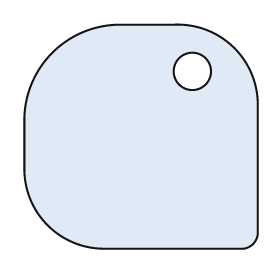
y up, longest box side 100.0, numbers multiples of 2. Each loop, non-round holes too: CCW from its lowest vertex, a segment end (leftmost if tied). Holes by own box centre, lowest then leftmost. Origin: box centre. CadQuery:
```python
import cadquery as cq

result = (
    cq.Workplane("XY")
    .moveTo(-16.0, -48.0)
    .lineTo(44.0, -48.0)
    .threePointArc((48.0, -46.0), (50.0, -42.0))
    .lineTo(50.0, 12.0)
    .threePointArc((40.0, 38.0), (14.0, 48.0))
    .lineTo(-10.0, 48.0)
    .threePointArc((-38.0, 36.0), (-50.0, 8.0))
    .lineTo(-50.0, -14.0)
    .threePointArc((-40.0, -38.0), (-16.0, -48.0))
    .close()
    .moveTo(22.0, 28.0)
    .circle(8.0)
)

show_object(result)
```